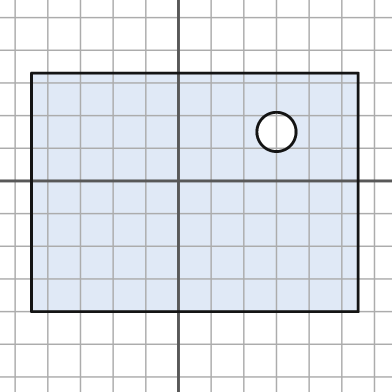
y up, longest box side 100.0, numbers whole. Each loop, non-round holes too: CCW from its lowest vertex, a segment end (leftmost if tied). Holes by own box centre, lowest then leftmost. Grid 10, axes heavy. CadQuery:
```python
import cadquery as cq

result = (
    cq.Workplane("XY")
    .moveTo(-45.0, -40.0)
    .lineTo(55.0, -40.0)
    .lineTo(55.0, 33.0)
    .lineTo(-45.0, 33.0)
    .close()
    .moveTo(30.0, 15.0)
    .circle(6.0)
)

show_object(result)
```